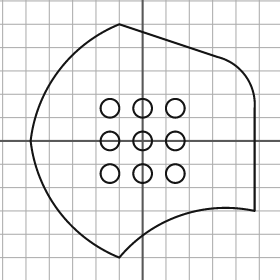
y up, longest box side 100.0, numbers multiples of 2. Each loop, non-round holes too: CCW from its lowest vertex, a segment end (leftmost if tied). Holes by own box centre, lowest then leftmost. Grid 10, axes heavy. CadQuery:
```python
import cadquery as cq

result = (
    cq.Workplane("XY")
    .moveTo(-10.0, -50.0)
    .threePointArc((16.0, -32.0), (48.0, -30.0))
    .lineTo(48.0, 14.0)
    .threePointArc((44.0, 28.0), (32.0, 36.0))
    .lineTo(-10.0, 50.0)
    .threePointArc((-36.0, 30.0), (-48.0, 0.0))
    .threePointArc((-36.0, -30.0), (-10.0, -50.0))
    .close()
    .moveTo(-14.0, -14.0)
    .circle(4.0)
    .moveTo(0.0, -14.0)
    .circle(4.0)
    .moveTo(14.0, -14.0)
    .circle(4.0)
    .moveTo(-14.0, 0.0)
    .circle(4.0)
    .moveTo(0.0, 0.0)
    .circle(4.0)
    .moveTo(14.0, 0.0)
    .circle(4.0)
    .moveTo(-14.0, 14.0)
    .circle(4.0)
    .moveTo(0.0, 14.0)
    .circle(4.0)
    .moveTo(14.0, 14.0)
    .circle(4.0)
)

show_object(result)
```